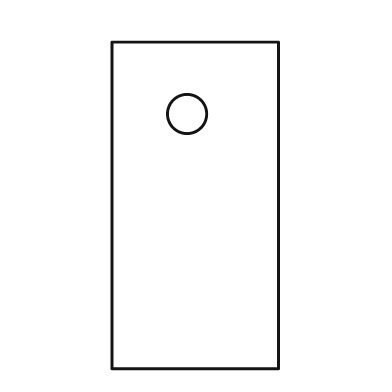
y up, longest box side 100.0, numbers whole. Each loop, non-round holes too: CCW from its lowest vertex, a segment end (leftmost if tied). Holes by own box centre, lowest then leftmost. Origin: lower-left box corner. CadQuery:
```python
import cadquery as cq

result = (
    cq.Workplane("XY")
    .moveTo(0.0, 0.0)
    .lineTo(51.0, 0.0)
    .lineTo(51.0, 100.0)
    .lineTo(0.0, 100.0)
    .close()
    .moveTo(23.0, 78.0)
    .circle(6.0)
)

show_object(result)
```